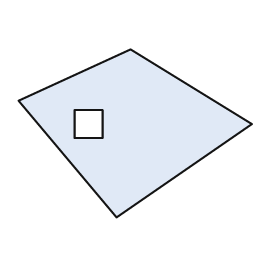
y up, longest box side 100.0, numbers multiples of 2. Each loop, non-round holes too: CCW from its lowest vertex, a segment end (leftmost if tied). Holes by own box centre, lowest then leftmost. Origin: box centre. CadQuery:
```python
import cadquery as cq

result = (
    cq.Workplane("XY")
    .moveTo(-8.0, -36.0)
    .lineTo(50.0, 4.0)
    .lineTo(-2.0, 36.0)
    .lineTo(-50.0, 14.0)
    .close()
    .moveTo(-26.0, -2.0)
    .lineTo(-14.0, -2.0)
    .lineTo(-14.0, 10.0)
    .lineTo(-26.0, 10.0)
    .close()
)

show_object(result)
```